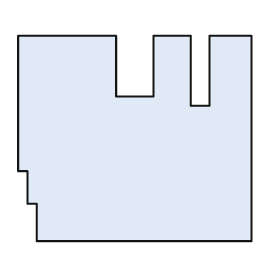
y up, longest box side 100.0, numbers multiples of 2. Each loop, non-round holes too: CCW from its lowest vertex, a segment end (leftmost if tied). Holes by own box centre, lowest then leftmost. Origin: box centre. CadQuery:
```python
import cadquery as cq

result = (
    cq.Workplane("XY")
    .moveTo(-42.0, -44.0)
    .lineTo(50.0, -44.0)
    .lineTo(50.0, 44.0)
    .lineTo(32.0, 44.0)
    .lineTo(32.0, 14.0)
    .lineTo(24.0, 14.0)
    .lineTo(24.0, 44.0)
    .lineTo(8.0, 44.0)
    .lineTo(8.0, 18.0)
    .lineTo(-8.0, 18.0)
    .lineTo(-8.0, 44.0)
    .lineTo(-50.0, 44.0)
    .lineTo(-50.0, -14.0)
    .lineTo(-46.0, -14.0)
    .lineTo(-46.0, -28.0)
    .lineTo(-42.0, -28.0)
    .close()
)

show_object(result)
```